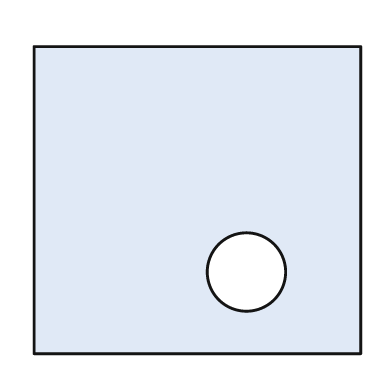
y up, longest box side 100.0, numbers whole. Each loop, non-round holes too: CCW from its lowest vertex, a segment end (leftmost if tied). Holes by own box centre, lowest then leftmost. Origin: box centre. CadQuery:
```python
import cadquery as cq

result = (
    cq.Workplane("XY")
    .moveTo(-50.0, -47.0)
    .lineTo(50.0, -47.0)
    .lineTo(50.0, 47.0)
    .lineTo(-50.0, 47.0)
    .close()
    .moveTo(15.0, -22.0)
    .circle(12.0)
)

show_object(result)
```